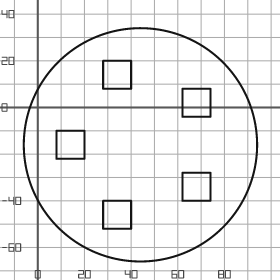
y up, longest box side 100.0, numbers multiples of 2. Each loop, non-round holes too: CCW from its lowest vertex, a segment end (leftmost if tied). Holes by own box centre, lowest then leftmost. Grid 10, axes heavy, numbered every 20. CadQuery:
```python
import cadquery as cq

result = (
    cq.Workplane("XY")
    .moveTo(44.0, -16.0)
    .circle(50.0)
    .moveTo(28.0, -52.0)
    .lineTo(40.0, -52.0)
    .lineTo(40.0, -40.0)
    .lineTo(28.0, -40.0)
    .close()
    .moveTo(62.0, -40.0)
    .lineTo(74.0, -40.0)
    .lineTo(74.0, -28.0)
    .lineTo(62.0, -28.0)
    .close()
    .moveTo(8.0, -22.0)
    .lineTo(20.0, -22.0)
    .lineTo(20.0, -10.0)
    .lineTo(8.0, -10.0)
    .close()
    .moveTo(62.0, -4.0)
    .lineTo(74.0, -4.0)
    .lineTo(74.0, 8.0)
    .lineTo(62.0, 8.0)
    .close()
    .moveTo(28.0, 8.0)
    .lineTo(40.0, 8.0)
    .lineTo(40.0, 20.0)
    .lineTo(28.0, 20.0)
    .close()
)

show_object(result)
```